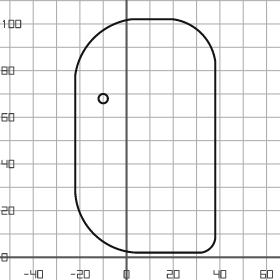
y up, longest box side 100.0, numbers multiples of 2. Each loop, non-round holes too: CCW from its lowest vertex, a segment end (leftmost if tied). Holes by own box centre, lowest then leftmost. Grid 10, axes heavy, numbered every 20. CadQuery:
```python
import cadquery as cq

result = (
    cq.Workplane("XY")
    .moveTo(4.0, 2.0)
    .lineTo(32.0, 2.0)
    .threePointArc((36.0, 4.0), (38.0, 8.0))
    .lineTo(38.0, 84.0)
    .threePointArc((32.0, 96.0), (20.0, 102.0))
    .lineTo(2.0, 102.0)
    .threePointArc((-14.0, 94.0), (-22.0, 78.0))
    .lineTo(-22.0, 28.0)
    .threePointArc((-14.0, 10.0), (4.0, 2.0))
    .close()
    .moveTo(-10.0, 68.0)
    .circle(2.0)
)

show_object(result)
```